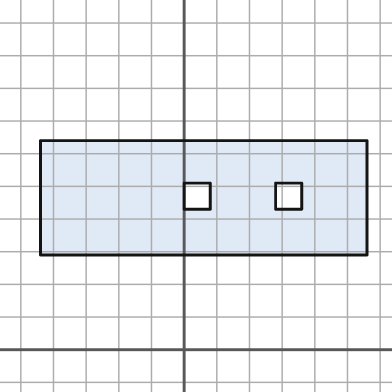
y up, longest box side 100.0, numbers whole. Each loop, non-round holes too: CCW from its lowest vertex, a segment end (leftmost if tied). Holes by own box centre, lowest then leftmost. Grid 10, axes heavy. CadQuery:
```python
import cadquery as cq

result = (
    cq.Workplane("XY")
    .moveTo(-44.0, 29.0)
    .lineTo(56.0, 29.0)
    .lineTo(56.0, 64.0)
    .lineTo(-44.0, 64.0)
    .close()
    .moveTo(0.0, 43.0)
    .lineTo(8.0, 43.0)
    .lineTo(8.0, 51.0)
    .lineTo(0.0, 51.0)
    .close()
    .moveTo(28.0, 43.0)
    .lineTo(36.0, 43.0)
    .lineTo(36.0, 51.0)
    .lineTo(28.0, 51.0)
    .close()
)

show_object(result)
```